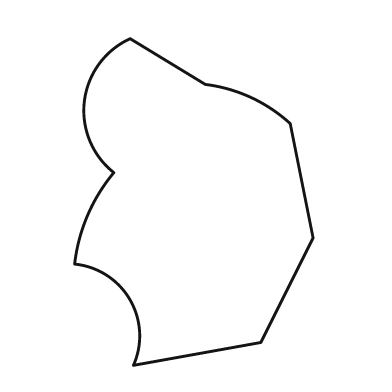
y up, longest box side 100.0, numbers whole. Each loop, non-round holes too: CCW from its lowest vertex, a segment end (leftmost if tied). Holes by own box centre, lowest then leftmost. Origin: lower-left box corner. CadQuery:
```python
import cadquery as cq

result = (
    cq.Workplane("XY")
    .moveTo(18.0, 0.0)
    .lineTo(57.0, 7.0)
    .lineTo(73.0, 39.0)
    .lineTo(66.0, 74.0)
    .threePointArc((54.0, 82.0), (40.0, 86.0))
    .lineTo(17.0, 100.0)
    .threePointArc((3.0, 81.0), (12.0, 59.0))
    .threePointArc((4.0, 46.0), (0.0, 31.0))
    .threePointArc((17.0, 20.0), (18.0, 0.0))
    .close()
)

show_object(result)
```